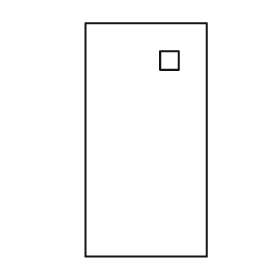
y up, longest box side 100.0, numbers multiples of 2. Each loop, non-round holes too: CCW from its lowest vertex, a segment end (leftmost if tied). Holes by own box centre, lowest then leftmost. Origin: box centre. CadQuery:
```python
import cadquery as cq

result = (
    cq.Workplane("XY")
    .moveTo(-26.0, -50.0)
    .lineTo(26.0, -50.0)
    .lineTo(26.0, 50.0)
    .lineTo(-26.0, 50.0)
    .close()
    .moveTo(6.0, 30.0)
    .lineTo(14.0, 30.0)
    .lineTo(14.0, 38.0)
    .lineTo(6.0, 38.0)
    .close()
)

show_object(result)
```